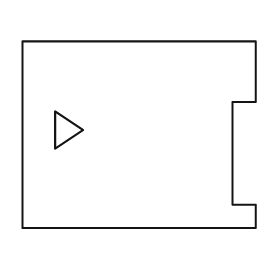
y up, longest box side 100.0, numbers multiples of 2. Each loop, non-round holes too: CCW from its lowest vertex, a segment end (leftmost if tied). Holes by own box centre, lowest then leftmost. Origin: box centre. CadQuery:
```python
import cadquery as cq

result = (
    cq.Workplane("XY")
    .moveTo(-50.0, -40.0)
    .lineTo(50.0, -40.0)
    .lineTo(50.0, -30.0)
    .lineTo(40.0, -30.0)
    .lineTo(40.0, 14.0)
    .lineTo(50.0, 14.0)
    .lineTo(50.0, 40.0)
    .lineTo(-50.0, 40.0)
    .close()
    .moveTo(-36.0, -6.0)
    .lineTo(-24.0, 2.0)
    .lineTo(-36.0, 10.0)
    .close()
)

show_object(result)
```